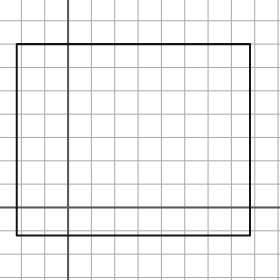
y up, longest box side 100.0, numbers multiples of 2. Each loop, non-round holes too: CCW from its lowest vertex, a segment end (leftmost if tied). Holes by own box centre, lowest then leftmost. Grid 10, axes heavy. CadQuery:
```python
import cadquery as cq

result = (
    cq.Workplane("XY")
    .moveTo(-22.0, -12.0)
    .lineTo(78.0, -12.0)
    .lineTo(78.0, 70.0)
    .lineTo(-22.0, 70.0)
    .close()
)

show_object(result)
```